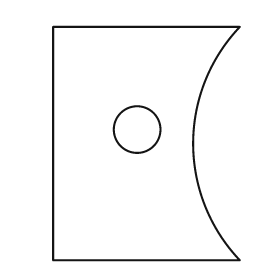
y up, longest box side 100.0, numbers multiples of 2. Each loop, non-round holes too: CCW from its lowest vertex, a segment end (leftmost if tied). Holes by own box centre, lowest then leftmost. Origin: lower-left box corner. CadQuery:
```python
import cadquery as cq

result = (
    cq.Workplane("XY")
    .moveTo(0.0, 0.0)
    .lineTo(80.0, 0.0)
    .threePointArc((60.0, 50.0), (80.0, 100.0))
    .lineTo(0.0, 100.0)
    .close()
    .moveTo(36.0, 56.0)
    .circle(10.0)
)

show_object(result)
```